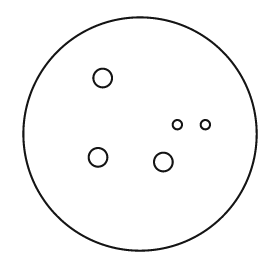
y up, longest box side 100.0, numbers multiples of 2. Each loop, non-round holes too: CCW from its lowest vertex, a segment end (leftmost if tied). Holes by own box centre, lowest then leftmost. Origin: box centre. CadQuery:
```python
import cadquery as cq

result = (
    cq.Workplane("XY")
    .moveTo(0.0, 0.0)
    .circle(50.0)
    .moveTo(10.0, -12.0)
    .circle(4.0)
    .moveTo(-18.0, -10.0)
    .circle(4.0)
    .moveTo(16.0, 4.0)
    .circle(2.0)
    .moveTo(28.0, 4.0)
    .circle(2.0)
    .moveTo(-16.0, 24.0)
    .circle(4.0)
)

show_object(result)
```